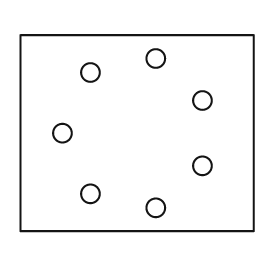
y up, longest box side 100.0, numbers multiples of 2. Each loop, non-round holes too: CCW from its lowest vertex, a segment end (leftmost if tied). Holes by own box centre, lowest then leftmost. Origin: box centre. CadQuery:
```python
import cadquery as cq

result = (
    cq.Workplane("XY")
    .moveTo(-50.0, -42.0)
    .lineTo(50.0, -42.0)
    .lineTo(50.0, 42.0)
    .lineTo(-50.0, 42.0)
    .close()
    .moveTo(8.0, -32.0)
    .circle(4.0)
    .moveTo(-20.0, -26.0)
    .circle(4.0)
    .moveTo(28.0, -14.0)
    .circle(4.0)
    .moveTo(-32.0, 0.0)
    .circle(4.0)
    .moveTo(28.0, 14.0)
    .circle(4.0)
    .moveTo(-20.0, 26.0)
    .circle(4.0)
    .moveTo(8.0, 32.0)
    .circle(4.0)
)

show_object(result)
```